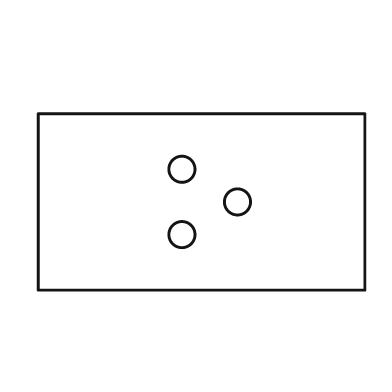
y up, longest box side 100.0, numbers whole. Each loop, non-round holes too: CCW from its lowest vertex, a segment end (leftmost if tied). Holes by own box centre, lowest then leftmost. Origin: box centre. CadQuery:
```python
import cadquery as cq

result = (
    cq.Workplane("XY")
    .moveTo(-50.0, -27.0)
    .lineTo(50.0, -27.0)
    .lineTo(50.0, 27.0)
    .lineTo(-50.0, 27.0)
    .close()
    .moveTo(-6.0, -10.0)
    .circle(4.0)
    .moveTo(11.0, 0.0)
    .circle(4.0)
    .moveTo(-6.0, 10.0)
    .circle(4.0)
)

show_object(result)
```